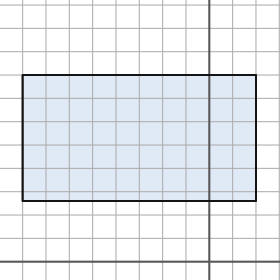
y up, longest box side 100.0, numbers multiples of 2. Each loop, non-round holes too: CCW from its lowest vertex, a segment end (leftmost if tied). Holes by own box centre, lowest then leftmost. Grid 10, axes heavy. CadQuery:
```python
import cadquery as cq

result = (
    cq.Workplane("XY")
    .moveTo(-80.0, 26.0)
    .lineTo(20.0, 26.0)
    .lineTo(20.0, 80.0)
    .lineTo(-80.0, 80.0)
    .close()
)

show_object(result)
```